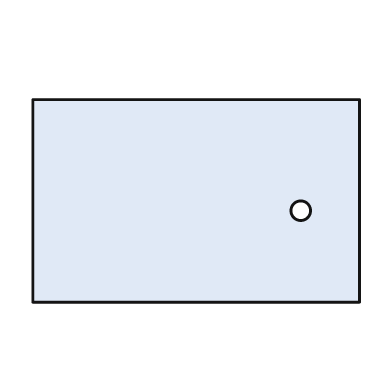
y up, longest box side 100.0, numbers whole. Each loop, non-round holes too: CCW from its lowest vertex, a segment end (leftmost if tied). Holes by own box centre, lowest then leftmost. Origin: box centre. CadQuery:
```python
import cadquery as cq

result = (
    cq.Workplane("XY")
    .moveTo(-50.0, -31.0)
    .lineTo(50.0, -31.0)
    .lineTo(50.0, 31.0)
    .lineTo(-50.0, 31.0)
    .close()
    .moveTo(32.0, -3.0)
    .circle(3.0)
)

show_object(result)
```